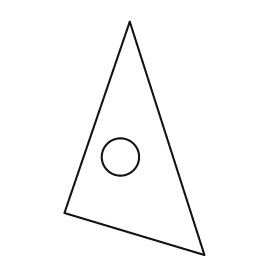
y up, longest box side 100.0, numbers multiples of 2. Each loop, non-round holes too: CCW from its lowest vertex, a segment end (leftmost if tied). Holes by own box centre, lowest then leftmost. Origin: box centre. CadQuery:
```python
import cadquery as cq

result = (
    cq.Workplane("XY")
    .moveTo(30.0, -50.0)
    .lineTo(-2.0, 50.0)
    .lineTo(-30.0, -32.0)
    .close()
    .moveTo(-6.0, -8.0)
    .circle(8.0)
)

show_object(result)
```